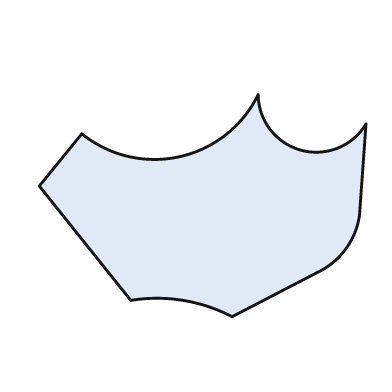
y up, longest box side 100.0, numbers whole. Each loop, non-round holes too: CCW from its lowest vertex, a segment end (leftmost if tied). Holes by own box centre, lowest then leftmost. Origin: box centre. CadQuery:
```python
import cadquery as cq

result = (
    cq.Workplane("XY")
    .moveTo(9.0, -34.0)
    .lineTo(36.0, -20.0)
    .threePointArc((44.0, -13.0), (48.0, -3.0))
    .lineTo(50.0, 25.0)
    .threePointArc((30.0, 17.0), (17.0, 34.0))
    .threePointArc((-7.0, 15.0), (-37.0, 22.0))
    .lineTo(-50.0, 6.0)
    .lineTo(-22.0, -29.0)
    .threePointArc((-6.0, -29.0), (9.0, -34.0))
    .close()
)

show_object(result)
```